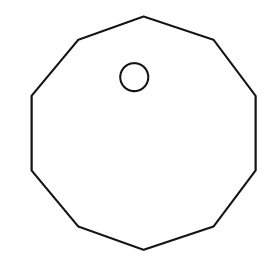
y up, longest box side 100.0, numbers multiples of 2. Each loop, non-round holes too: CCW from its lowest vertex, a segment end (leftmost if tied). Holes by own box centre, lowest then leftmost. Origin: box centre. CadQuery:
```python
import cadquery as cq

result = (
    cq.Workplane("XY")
    .moveTo(0.0, -50.0)
    .lineTo(30.0, -40.0)
    .lineTo(48.0, -16.0)
    .lineTo(48.0, 16.0)
    .lineTo(30.0, 40.0)
    .lineTo(0.0, 50.0)
    .lineTo(-28.0, 40.0)
    .lineTo(-48.0, 16.0)
    .lineTo(-48.0, -16.0)
    .lineTo(-28.0, -40.0)
    .close()
    .moveTo(-4.0, 24.0)
    .circle(6.0)
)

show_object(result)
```